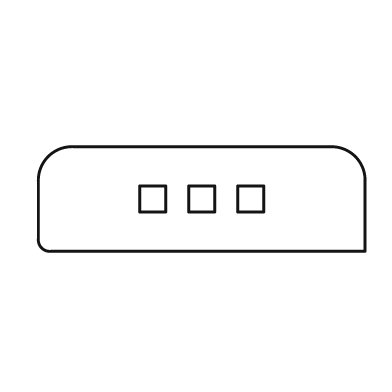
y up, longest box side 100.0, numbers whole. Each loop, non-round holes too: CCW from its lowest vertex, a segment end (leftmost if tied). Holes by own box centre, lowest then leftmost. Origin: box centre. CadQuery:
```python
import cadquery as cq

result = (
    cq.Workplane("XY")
    .moveTo(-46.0, -16.0)
    .lineTo(50.0, -16.0)
    .lineTo(50.0, 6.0)
    .threePointArc((47.0, 13.0), (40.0, 16.0))
    .lineTo(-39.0, 16.0)
    .threePointArc((-47.0, 13.0), (-50.0, 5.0))
    .lineTo(-50.0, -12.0)
    .threePointArc((-49.0, -15.0), (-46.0, -16.0))
    .close()
    .moveTo(-19.0, -4.0)
    .lineTo(-11.0, -4.0)
    .lineTo(-11.0, 4.0)
    .lineTo(-19.0, 4.0)
    .close()
    .moveTo(-4.0, -4.0)
    .lineTo(4.0, -4.0)
    .lineTo(4.0, 4.0)
    .lineTo(-4.0, 4.0)
    .close()
    .moveTo(11.0, -4.0)
    .lineTo(19.0, -4.0)
    .lineTo(19.0, 4.0)
    .lineTo(11.0, 4.0)
    .close()
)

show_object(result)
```